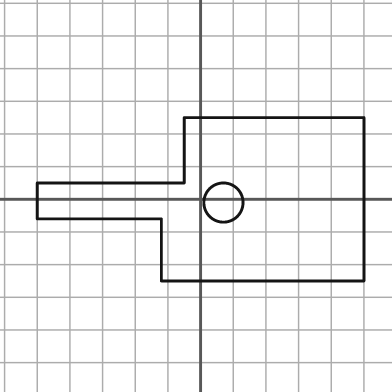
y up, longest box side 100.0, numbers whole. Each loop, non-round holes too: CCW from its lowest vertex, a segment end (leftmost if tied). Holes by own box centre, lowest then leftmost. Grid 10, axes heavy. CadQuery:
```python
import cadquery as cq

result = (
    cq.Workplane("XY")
    .moveTo(-12.0, -25.0)
    .lineTo(50.0, -25.0)
    .lineTo(50.0, 25.0)
    .lineTo(-5.0, 25.0)
    .lineTo(-5.0, 5.0)
    .lineTo(-50.0, 5.0)
    .lineTo(-50.0, -6.0)
    .lineTo(-12.0, -6.0)
    .close()
    .moveTo(7.0, -1.0)
    .circle(6.0)
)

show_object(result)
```